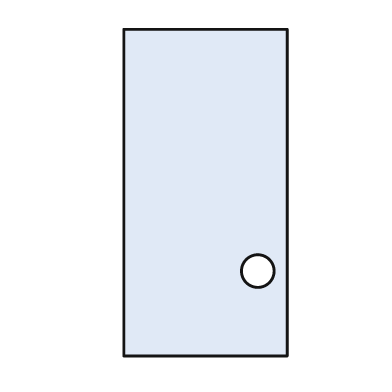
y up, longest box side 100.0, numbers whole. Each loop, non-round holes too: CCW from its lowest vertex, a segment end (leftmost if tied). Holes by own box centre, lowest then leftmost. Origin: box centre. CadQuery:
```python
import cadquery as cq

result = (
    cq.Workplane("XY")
    .moveTo(-25.0, -50.0)
    .lineTo(25.0, -50.0)
    .lineTo(25.0, 50.0)
    .lineTo(-25.0, 50.0)
    .close()
    .moveTo(16.0, -24.0)
    .circle(5.0)
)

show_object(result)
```